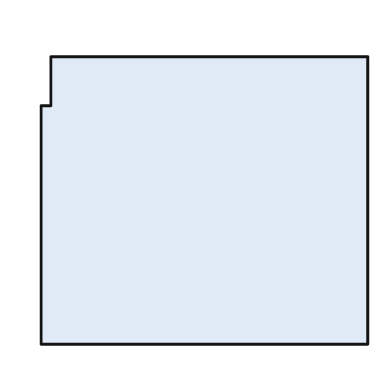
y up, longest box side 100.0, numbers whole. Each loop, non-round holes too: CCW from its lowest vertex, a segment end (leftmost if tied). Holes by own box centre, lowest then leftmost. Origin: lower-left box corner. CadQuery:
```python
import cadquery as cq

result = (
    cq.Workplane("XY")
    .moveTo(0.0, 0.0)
    .lineTo(100.0, 0.0)
    .lineTo(100.0, 88.0)
    .lineTo(3.0, 88.0)
    .lineTo(3.0, 73.0)
    .lineTo(0.0, 73.0)
    .close()
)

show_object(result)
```